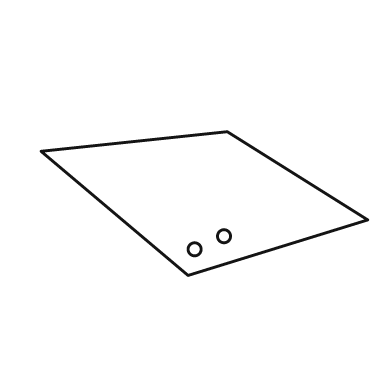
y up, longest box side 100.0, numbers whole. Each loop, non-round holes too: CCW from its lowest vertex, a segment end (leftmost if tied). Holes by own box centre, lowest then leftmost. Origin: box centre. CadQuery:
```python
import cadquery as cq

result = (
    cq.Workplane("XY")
    .moveTo(-5.0, -22.0)
    .lineTo(50.0, -5.0)
    .lineTo(7.0, 22.0)
    .lineTo(-50.0, 16.0)
    .close()
    .moveTo(-3.0, -14.0)
    .circle(2.0)
    .moveTo(6.0, -10.0)
    .circle(2.0)
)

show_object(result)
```